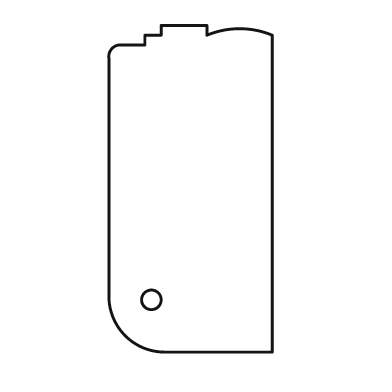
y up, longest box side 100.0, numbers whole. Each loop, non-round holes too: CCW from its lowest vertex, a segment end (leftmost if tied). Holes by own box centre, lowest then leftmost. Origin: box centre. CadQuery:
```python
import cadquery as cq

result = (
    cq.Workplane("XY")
    .moveTo(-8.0, -50.0)
    .lineTo(25.0, -50.0)
    .lineTo(25.0, 47.0)
    .threePointArc((15.0, 49.0), (5.0, 47.0))
    .lineTo(5.0, 50.0)
    .lineTo(-9.0, 50.0)
    .lineTo(-9.0, 47.0)
    .lineTo(-14.0, 47.0)
    .lineTo(-14.0, 44.0)
    .lineTo(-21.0, 44.0)
    .threePointArc((-24.0, 43.0), (-25.0, 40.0))
    .lineTo(-25.0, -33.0)
    .threePointArc((-20.0, -45.0), (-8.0, -50.0))
    .close()
    .moveTo(-12.0, -34.0)
    .circle(3.0)
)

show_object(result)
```